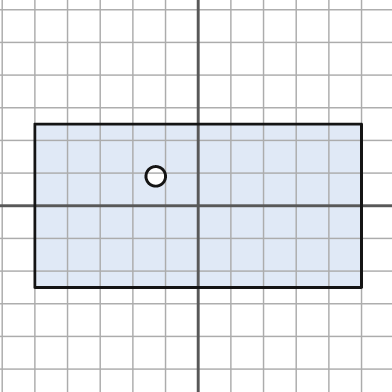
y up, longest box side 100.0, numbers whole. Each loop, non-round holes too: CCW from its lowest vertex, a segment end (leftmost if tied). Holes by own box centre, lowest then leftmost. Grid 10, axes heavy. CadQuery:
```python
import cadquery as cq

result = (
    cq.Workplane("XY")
    .moveTo(-50.0, -25.0)
    .lineTo(50.0, -25.0)
    .lineTo(50.0, 25.0)
    .lineTo(-50.0, 25.0)
    .close()
    .moveTo(-13.0, 9.0)
    .circle(3.0)
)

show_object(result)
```